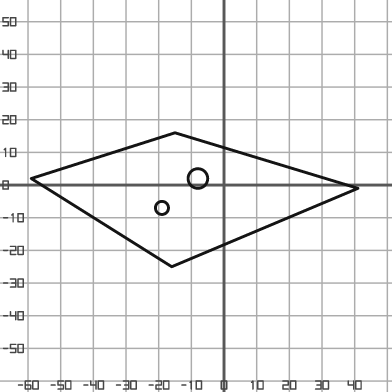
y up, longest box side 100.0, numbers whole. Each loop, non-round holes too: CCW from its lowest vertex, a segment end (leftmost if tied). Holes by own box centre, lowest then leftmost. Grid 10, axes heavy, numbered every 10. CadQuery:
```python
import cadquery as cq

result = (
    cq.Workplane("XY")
    .moveTo(-16.0, -25.0)
    .lineTo(41.0, -1.0)
    .lineTo(-15.0, 16.0)
    .lineTo(-59.0, 2.0)
    .close()
    .moveTo(-19.0, -7.0)
    .circle(2.0)
    .moveTo(-8.0, 2.0)
    .circle(3.0)
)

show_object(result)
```